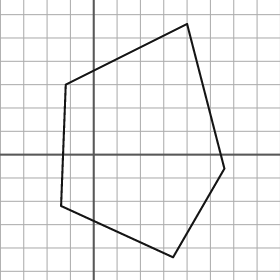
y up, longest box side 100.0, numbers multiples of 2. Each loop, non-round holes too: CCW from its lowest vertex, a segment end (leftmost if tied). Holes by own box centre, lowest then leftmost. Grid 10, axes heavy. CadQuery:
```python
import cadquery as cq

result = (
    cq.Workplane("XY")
    .moveTo(34.0, -44.0)
    .lineTo(56.0, -6.0)
    .lineTo(40.0, 56.0)
    .lineTo(-12.0, 30.0)
    .lineTo(-14.0, -22.0)
    .close()
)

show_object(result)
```